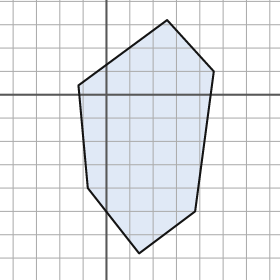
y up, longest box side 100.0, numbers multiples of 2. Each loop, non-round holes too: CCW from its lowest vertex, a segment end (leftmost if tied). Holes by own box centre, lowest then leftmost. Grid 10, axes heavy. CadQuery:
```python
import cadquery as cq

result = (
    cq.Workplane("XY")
    .moveTo(14.0, -68.0)
    .lineTo(38.0, -50.0)
    .lineTo(46.0, 10.0)
    .lineTo(26.0, 32.0)
    .lineTo(-12.0, 4.0)
    .lineTo(-8.0, -40.0)
    .close()
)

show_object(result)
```